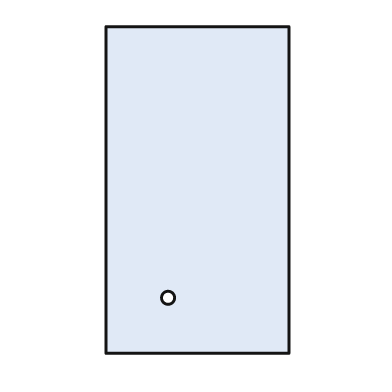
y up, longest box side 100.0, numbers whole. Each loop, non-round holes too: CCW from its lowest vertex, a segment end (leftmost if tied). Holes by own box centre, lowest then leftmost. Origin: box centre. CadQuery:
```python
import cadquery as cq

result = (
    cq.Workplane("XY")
    .moveTo(-28.0, -50.0)
    .lineTo(28.0, -50.0)
    .lineTo(28.0, 50.0)
    .lineTo(-28.0, 50.0)
    .close()
    .moveTo(-9.0, -33.0)
    .circle(2.0)
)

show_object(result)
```